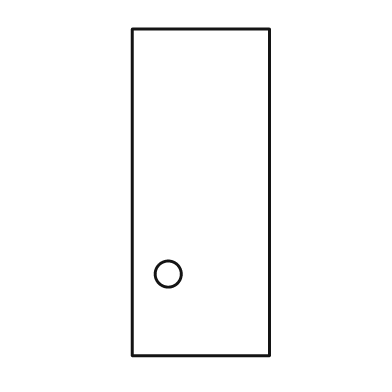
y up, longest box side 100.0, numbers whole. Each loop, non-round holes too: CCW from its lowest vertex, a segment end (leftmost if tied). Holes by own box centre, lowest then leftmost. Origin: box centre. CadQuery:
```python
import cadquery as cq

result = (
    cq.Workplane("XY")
    .moveTo(-21.0, -50.0)
    .lineTo(21.0, -50.0)
    .lineTo(21.0, 50.0)
    .lineTo(-21.0, 50.0)
    .close()
    .moveTo(-10.0, -25.0)
    .circle(4.0)
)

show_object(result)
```